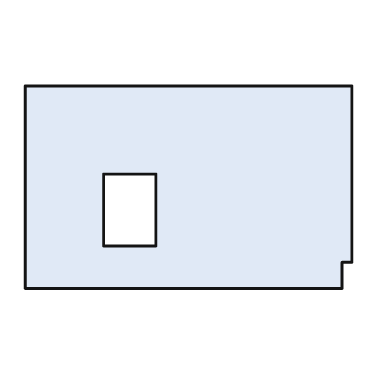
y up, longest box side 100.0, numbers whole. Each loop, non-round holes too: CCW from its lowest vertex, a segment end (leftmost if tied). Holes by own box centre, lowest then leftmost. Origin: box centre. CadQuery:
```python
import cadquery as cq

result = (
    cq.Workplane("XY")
    .moveTo(-50.0, -31.0)
    .lineTo(47.0, -31.0)
    .lineTo(47.0, -23.0)
    .lineTo(50.0, -23.0)
    .lineTo(50.0, 31.0)
    .lineTo(-50.0, 31.0)
    .close()
    .moveTo(-26.0, -18.0)
    .lineTo(-10.0, -18.0)
    .lineTo(-10.0, 4.0)
    .lineTo(-26.0, 4.0)
    .close()
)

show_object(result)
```